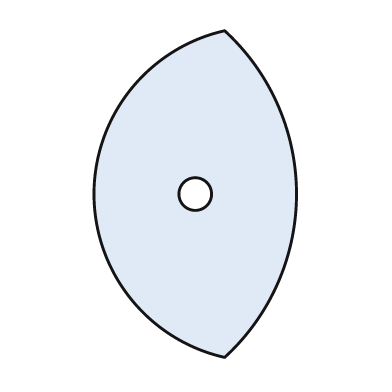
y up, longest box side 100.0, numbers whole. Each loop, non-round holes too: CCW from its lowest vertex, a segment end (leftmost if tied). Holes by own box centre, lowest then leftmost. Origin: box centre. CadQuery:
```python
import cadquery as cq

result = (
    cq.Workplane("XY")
    .moveTo(9.0, -50.0)
    .threePointArc((31.0, 0.0), (9.0, 50.0))
    .threePointArc((-31.0, 0.0), (9.0, -50.0))
    .close()
    .moveTo(0.0, 0.0)
    .circle(5.0)
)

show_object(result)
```